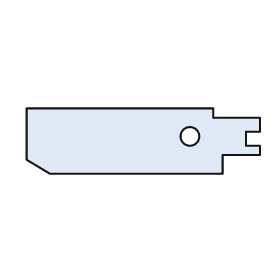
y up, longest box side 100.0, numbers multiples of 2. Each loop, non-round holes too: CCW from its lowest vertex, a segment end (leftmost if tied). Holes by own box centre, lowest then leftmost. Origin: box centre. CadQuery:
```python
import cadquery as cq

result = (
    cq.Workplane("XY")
    .moveTo(-40.0, -14.0)
    .lineTo(34.0, -14.0)
    .lineTo(34.0, -6.0)
    .lineTo(50.0, -6.0)
    .lineTo(50.0, -2.0)
    .lineTo(44.0, -2.0)
    .lineTo(44.0, 4.0)
    .lineTo(50.0, 4.0)
    .lineTo(50.0, 10.0)
    .lineTo(30.0, 10.0)
    .lineTo(30.0, 14.0)
    .lineTo(-50.0, 14.0)
    .lineTo(-50.0, -8.0)
    .close()
    .moveTo(20.0, 2.0)
    .circle(4.0)
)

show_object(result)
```